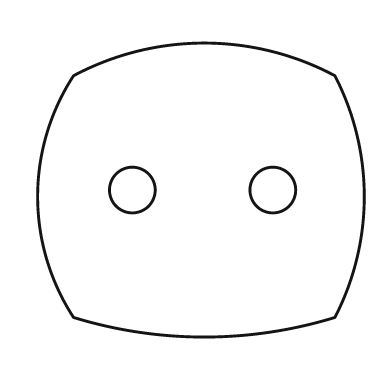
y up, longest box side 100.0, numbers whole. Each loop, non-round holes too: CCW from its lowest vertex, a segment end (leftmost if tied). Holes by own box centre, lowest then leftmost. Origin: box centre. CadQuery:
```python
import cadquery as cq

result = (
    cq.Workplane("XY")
    .moveTo(-39.0, -39.0)
    .threePointArc((1.0, -45.0), (41.0, -39.0))
    .threePointArc((50.0, -2.0), (41.0, 35.0))
    .threePointArc((1.0, 45.0), (-39.0, 35.0))
    .threePointArc((-50.0, -2.0), (-39.0, -39.0))
    .close()
    .moveTo(-21.0, 0.0)
    .circle(7.0)
    .moveTo(22.0, 0.0)
    .circle(7.0)
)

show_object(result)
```